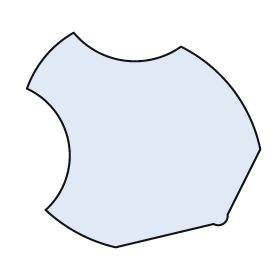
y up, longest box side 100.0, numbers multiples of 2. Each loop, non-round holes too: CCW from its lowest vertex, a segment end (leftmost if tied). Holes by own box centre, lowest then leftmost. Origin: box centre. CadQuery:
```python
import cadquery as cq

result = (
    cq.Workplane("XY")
    .moveTo(-12.0, -46.0)
    .lineTo(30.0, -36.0)
    .threePointArc((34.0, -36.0), (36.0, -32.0))
    .lineTo(50.0, -4.0)
    .threePointArc((38.0, 22.0), (16.0, 40.0))
    .threePointArc((-8.0, 34.0), (-30.0, 46.0))
    .threePointArc((-42.0, 36.0), (-50.0, 22.0))
    .threePointArc((-32.0, -2.0), (-42.0, -30.0))
    .threePointArc((-28.0, -40.0), (-12.0, -46.0))
    .close()
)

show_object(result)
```